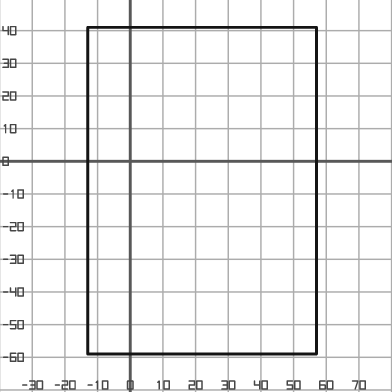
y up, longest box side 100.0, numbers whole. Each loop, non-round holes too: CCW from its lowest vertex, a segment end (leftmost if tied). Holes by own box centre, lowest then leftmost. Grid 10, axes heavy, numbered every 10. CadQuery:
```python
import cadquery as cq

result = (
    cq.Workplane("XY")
    .moveTo(-13.0, -59.0)
    .lineTo(57.0, -59.0)
    .lineTo(57.0, 41.0)
    .lineTo(-13.0, 41.0)
    .close()
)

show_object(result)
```